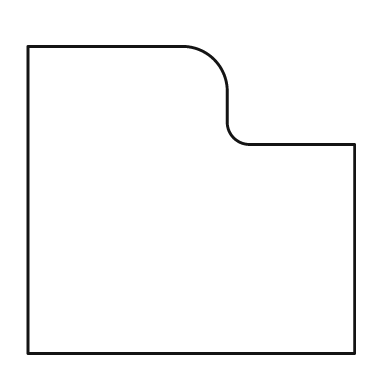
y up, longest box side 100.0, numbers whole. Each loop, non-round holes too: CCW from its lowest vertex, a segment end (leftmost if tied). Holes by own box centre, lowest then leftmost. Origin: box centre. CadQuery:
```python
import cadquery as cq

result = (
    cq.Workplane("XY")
    .moveTo(-50.0, -47.0)
    .lineTo(50.0, -47.0)
    .lineTo(50.0, 17.0)
    .lineTo(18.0, 17.0)
    .threePointArc((13.0, 19.0), (11.0, 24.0))
    .lineTo(11.0, 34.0)
    .threePointArc((7.0, 43.0), (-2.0, 47.0))
    .lineTo(-50.0, 47.0)
    .close()
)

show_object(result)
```